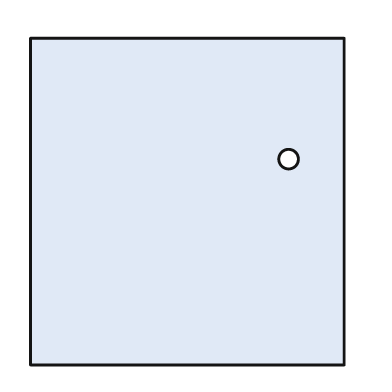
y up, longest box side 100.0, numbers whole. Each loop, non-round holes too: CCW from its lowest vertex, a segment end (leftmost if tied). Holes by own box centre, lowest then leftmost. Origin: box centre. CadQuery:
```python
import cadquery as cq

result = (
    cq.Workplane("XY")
    .moveTo(-48.0, -50.0)
    .lineTo(48.0, -50.0)
    .lineTo(48.0, 50.0)
    .lineTo(-48.0, 50.0)
    .close()
    .moveTo(31.0, 13.0)
    .circle(3.0)
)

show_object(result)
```